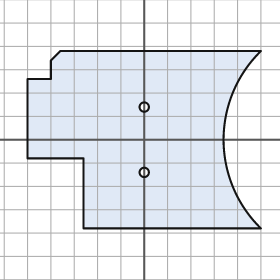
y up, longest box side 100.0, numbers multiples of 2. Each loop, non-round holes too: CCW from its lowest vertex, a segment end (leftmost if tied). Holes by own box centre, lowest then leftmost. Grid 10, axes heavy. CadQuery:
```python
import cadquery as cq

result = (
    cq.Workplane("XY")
    .moveTo(-26.0, -38.0)
    .lineTo(50.0, -38.0)
    .threePointArc((34.0, 0.0), (50.0, 38.0))
    .lineTo(-36.0, 38.0)
    .lineTo(-40.0, 34.0)
    .lineTo(-40.0, 26.0)
    .lineTo(-50.0, 26.0)
    .lineTo(-50.0, -8.0)
    .lineTo(-26.0, -8.0)
    .close()
    .moveTo(0.0, -14.0)
    .circle(2.0)
    .moveTo(0.0, 14.0)
    .circle(2.0)
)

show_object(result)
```